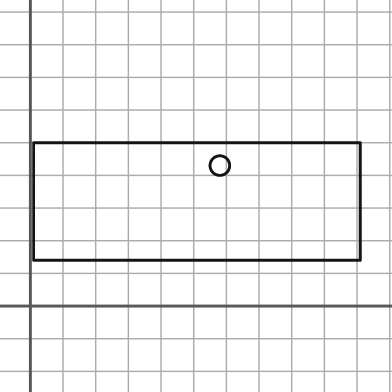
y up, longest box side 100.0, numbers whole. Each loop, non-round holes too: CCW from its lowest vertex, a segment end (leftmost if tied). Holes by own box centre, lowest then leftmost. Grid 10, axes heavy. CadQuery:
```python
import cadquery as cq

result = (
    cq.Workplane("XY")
    .moveTo(1.0, 14.0)
    .lineTo(101.0, 14.0)
    .lineTo(101.0, 50.0)
    .lineTo(1.0, 50.0)
    .close()
    .moveTo(58.0, 43.0)
    .circle(3.0)
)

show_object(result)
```